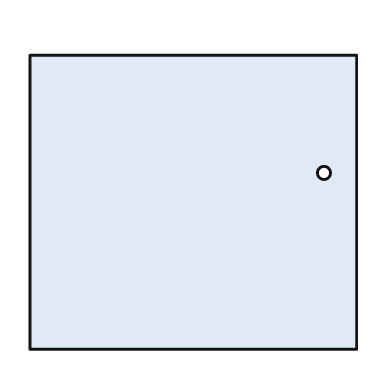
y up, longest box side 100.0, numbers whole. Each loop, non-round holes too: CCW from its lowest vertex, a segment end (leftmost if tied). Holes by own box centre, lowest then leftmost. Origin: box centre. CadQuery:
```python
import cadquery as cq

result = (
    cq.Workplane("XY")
    .moveTo(-50.0, -45.0)
    .lineTo(50.0, -45.0)
    .lineTo(50.0, 45.0)
    .lineTo(-50.0, 45.0)
    .close()
    .moveTo(40.0, 9.0)
    .circle(2.0)
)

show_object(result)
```